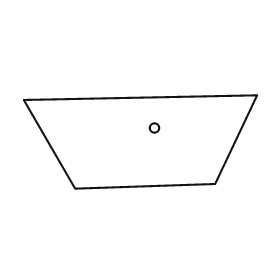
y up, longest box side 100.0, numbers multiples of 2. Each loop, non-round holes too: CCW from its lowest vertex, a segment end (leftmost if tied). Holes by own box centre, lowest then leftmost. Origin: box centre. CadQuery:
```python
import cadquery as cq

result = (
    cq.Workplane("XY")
    .moveTo(-28.0, -20.0)
    .lineTo(32.0, -18.0)
    .lineTo(50.0, 20.0)
    .lineTo(-50.0, 18.0)
    .close()
    .moveTo(6.0, 6.0)
    .circle(2.0)
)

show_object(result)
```